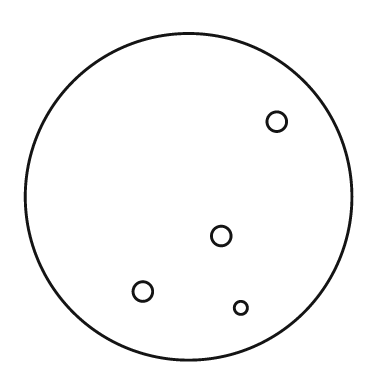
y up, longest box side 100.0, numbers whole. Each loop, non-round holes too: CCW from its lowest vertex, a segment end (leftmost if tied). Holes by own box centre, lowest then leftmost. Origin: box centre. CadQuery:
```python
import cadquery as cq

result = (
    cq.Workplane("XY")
    .moveTo(0.0, 0.0)
    .circle(50.0)
    .moveTo(16.0, -34.0)
    .circle(2.0)
    .moveTo(-14.0, -29.0)
    .circle(3.0)
    .moveTo(10.0, -12.0)
    .circle(3.0)
    .moveTo(27.0, 23.0)
    .circle(3.0)
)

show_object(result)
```